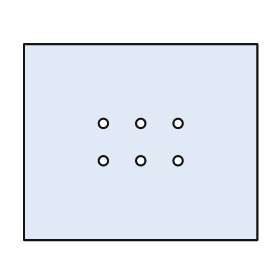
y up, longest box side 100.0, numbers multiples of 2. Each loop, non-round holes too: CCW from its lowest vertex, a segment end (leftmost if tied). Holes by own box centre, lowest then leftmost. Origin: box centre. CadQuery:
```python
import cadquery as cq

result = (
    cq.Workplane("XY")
    .moveTo(-50.0, -42.0)
    .lineTo(50.0, -42.0)
    .lineTo(50.0, 42.0)
    .lineTo(-50.0, 42.0)
    .close()
    .moveTo(-16.0, -8.0)
    .circle(2.0)
    .moveTo(0.0, -8.0)
    .circle(2.0)
    .moveTo(16.0, -8.0)
    .circle(2.0)
    .moveTo(-16.0, 8.0)
    .circle(2.0)
    .moveTo(0.0, 8.0)
    .circle(2.0)
    .moveTo(16.0, 8.0)
    .circle(2.0)
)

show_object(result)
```